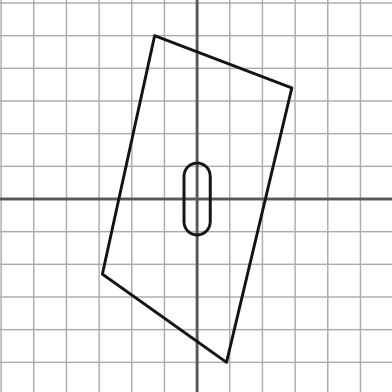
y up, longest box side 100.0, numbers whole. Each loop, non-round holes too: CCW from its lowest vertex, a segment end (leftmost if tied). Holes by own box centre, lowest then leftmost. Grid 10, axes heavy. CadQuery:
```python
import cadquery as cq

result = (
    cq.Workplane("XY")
    .moveTo(9.0, -50.0)
    .lineTo(29.0, 34.0)
    .lineTo(-13.0, 50.0)
    .lineTo(-29.0, -23.0)
    .close()
    .moveTo(-4.0, -7.0)
    .threePointArc((0.0, -11.0), (4.0, -7.0))
    .lineTo(4.0, 7.0)
    .threePointArc((0.0, 11.0), (-4.0, 7.0))
    .close()
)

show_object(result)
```